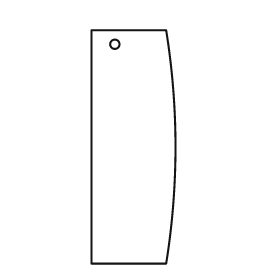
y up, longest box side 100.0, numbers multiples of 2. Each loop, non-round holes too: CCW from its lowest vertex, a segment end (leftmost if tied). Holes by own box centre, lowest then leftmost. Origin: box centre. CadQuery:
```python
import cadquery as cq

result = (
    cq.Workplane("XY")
    .moveTo(-18.0, -50.0)
    .lineTo(14.0, -50.0)
    .threePointArc((18.0, 0.0), (14.0, 50.0))
    .lineTo(-18.0, 50.0)
    .close()
    .moveTo(-8.0, 44.0)
    .circle(2.0)
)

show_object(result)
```